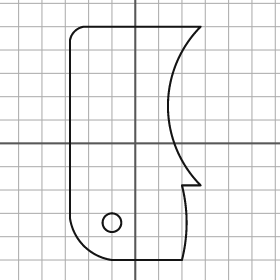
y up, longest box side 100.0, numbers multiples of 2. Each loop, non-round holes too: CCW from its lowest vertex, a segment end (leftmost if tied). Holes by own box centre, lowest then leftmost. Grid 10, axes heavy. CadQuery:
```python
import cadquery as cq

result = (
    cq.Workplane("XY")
    .moveTo(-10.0, -50.0)
    .lineTo(20.0, -50.0)
    .threePointArc((22.0, -34.0), (20.0, -18.0))
    .lineTo(28.0, -18.0)
    .threePointArc((14.0, 16.0), (28.0, 50.0))
    .lineTo(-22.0, 50.0)
    .threePointArc((-26.0, 48.0), (-28.0, 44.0))
    .lineTo(-28.0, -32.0)
    .threePointArc((-22.0, -44.0), (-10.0, -50.0))
    .close()
    .moveTo(-10.0, -34.0)
    .circle(4.0)
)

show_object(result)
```